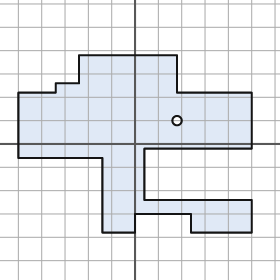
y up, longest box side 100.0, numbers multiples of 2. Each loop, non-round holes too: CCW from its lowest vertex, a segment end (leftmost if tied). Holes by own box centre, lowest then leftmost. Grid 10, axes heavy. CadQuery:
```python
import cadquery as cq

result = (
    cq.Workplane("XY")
    .moveTo(-14.0, -38.0)
    .lineTo(0.0, -38.0)
    .lineTo(0.0, -30.0)
    .lineTo(24.0, -30.0)
    .lineTo(24.0, -38.0)
    .lineTo(50.0, -38.0)
    .lineTo(50.0, -24.0)
    .lineTo(4.0, -24.0)
    .lineTo(4.0, -2.0)
    .lineTo(50.0, -2.0)
    .lineTo(50.0, 22.0)
    .lineTo(18.0, 22.0)
    .lineTo(18.0, 38.0)
    .lineTo(-24.0, 38.0)
    .lineTo(-24.0, 26.0)
    .lineTo(-34.0, 26.0)
    .lineTo(-34.0, 22.0)
    .lineTo(-50.0, 22.0)
    .lineTo(-50.0, -6.0)
    .lineTo(-14.0, -6.0)
    .close()
    .moveTo(18.0, 10.0)
    .circle(2.0)
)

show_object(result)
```